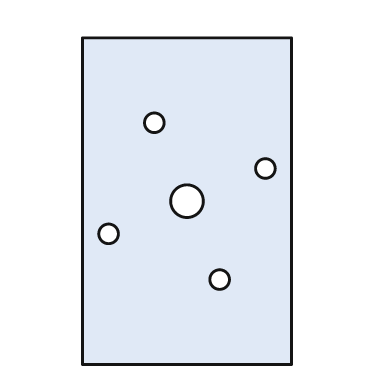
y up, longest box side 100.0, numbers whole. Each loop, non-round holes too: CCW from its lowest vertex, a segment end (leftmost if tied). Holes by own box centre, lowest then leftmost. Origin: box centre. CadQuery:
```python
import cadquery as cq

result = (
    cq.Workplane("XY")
    .moveTo(-32.0, -50.0)
    .lineTo(32.0, -50.0)
    .lineTo(32.0, 50.0)
    .lineTo(-32.0, 50.0)
    .close()
    .moveTo(10.0, -24.0)
    .circle(3.0)
    .moveTo(-24.0, -10.0)
    .circle(3.0)
    .moveTo(0.0, 0.0)
    .circle(5.0)
    .moveTo(24.0, 10.0)
    .circle(3.0)
    .moveTo(-10.0, 24.0)
    .circle(3.0)
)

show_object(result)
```